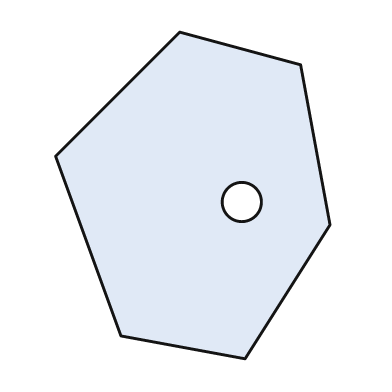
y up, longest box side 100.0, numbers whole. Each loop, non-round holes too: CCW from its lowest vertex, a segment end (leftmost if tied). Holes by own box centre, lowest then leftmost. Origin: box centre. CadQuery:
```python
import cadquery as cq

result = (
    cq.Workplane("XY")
    .moveTo(16.0, -50.0)
    .lineTo(42.0, -9.0)
    .lineTo(33.0, 40.0)
    .lineTo(-4.0, 50.0)
    .lineTo(-42.0, 12.0)
    .lineTo(-22.0, -43.0)
    .close()
    .moveTo(15.0, -2.0)
    .circle(6.0)
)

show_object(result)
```